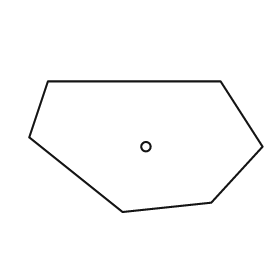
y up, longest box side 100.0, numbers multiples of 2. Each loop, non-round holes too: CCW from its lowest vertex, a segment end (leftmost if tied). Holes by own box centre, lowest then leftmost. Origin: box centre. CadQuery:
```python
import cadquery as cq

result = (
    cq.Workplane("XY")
    .moveTo(-10.0, -28.0)
    .lineTo(28.0, -24.0)
    .lineTo(50.0, 0.0)
    .lineTo(32.0, 28.0)
    .lineTo(-42.0, 28.0)
    .lineTo(-50.0, 4.0)
    .close()
    .moveTo(0.0, 0.0)
    .circle(2.0)
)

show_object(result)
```